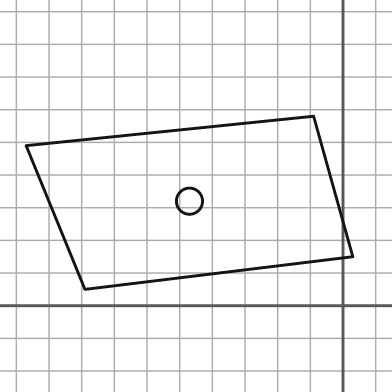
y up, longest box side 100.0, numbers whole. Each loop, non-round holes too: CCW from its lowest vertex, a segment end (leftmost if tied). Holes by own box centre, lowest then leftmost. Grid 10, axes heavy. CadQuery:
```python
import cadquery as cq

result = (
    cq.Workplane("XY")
    .moveTo(-79.0, 5.0)
    .lineTo(3.0, 15.0)
    .lineTo(-9.0, 58.0)
    .lineTo(-97.0, 49.0)
    .close()
    .moveTo(-47.0, 32.0)
    .circle(4.0)
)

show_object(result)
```